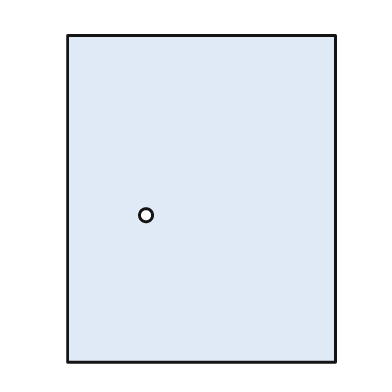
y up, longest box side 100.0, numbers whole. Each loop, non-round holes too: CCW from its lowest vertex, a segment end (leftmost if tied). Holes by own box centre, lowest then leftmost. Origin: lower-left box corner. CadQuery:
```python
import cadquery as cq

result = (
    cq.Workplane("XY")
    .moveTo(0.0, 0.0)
    .lineTo(82.0, 0.0)
    .lineTo(82.0, 100.0)
    .lineTo(0.0, 100.0)
    .close()
    .moveTo(24.0, 45.0)
    .circle(2.0)
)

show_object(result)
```